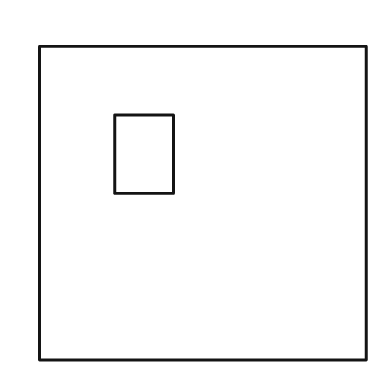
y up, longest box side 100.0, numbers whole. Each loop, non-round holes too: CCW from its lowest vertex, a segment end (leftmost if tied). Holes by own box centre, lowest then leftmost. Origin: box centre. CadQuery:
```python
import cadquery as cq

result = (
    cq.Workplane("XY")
    .moveTo(-50.0, -48.0)
    .lineTo(50.0, -48.0)
    .lineTo(50.0, 48.0)
    .lineTo(-50.0, 48.0)
    .close()
    .moveTo(-27.0, 3.0)
    .lineTo(-9.0, 3.0)
    .lineTo(-9.0, 27.0)
    .lineTo(-27.0, 27.0)
    .close()
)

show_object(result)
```